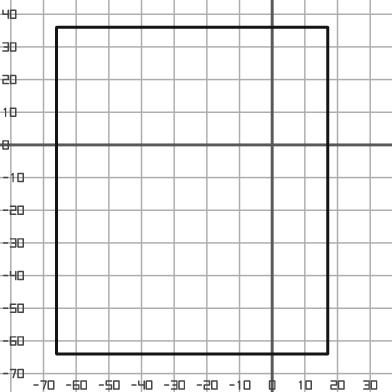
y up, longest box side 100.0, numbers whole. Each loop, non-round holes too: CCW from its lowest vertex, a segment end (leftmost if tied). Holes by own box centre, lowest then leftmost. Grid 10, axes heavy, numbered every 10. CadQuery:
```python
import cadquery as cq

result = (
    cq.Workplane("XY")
    .moveTo(-66.0, -64.0)
    .lineTo(17.0, -64.0)
    .lineTo(17.0, 36.0)
    .lineTo(-66.0, 36.0)
    .close()
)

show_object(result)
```